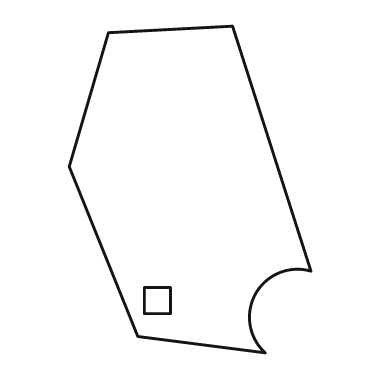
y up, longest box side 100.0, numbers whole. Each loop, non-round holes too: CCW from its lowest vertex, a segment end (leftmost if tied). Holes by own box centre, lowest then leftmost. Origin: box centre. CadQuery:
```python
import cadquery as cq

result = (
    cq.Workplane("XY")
    .moveTo(23.0, -50.0)
    .threePointArc((20.0, -32.0), (37.0, -25.0))
    .lineTo(13.0, 50.0)
    .lineTo(-25.0, 48.0)
    .lineTo(-37.0, 7.0)
    .lineTo(-16.0, -45.0)
    .close()
    .moveTo(-14.0, -38.0)
    .lineTo(-6.0, -38.0)
    .lineTo(-6.0, -30.0)
    .lineTo(-14.0, -30.0)
    .close()
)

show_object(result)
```